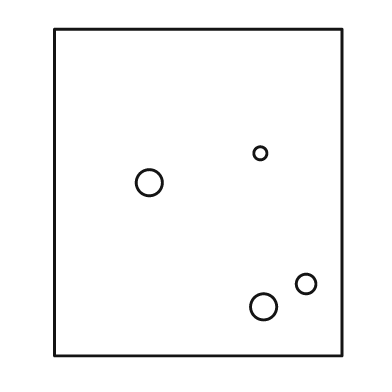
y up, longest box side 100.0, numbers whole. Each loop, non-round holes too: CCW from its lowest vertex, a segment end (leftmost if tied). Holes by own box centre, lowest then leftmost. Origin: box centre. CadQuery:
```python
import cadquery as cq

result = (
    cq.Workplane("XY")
    .moveTo(-44.0, -50.0)
    .lineTo(44.0, -50.0)
    .lineTo(44.0, 50.0)
    .lineTo(-44.0, 50.0)
    .close()
    .moveTo(20.0, -35.0)
    .circle(4.0)
    .moveTo(33.0, -28.0)
    .circle(3.0)
    .moveTo(-15.0, 3.0)
    .circle(4.0)
    .moveTo(19.0, 12.0)
    .circle(2.0)
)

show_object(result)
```